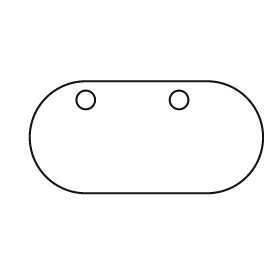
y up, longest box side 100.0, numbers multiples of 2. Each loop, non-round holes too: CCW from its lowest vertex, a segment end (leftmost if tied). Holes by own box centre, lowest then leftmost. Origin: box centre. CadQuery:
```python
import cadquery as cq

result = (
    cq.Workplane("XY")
    .moveTo(-26.0, -24.0)
    .lineTo(26.0, -24.0)
    .threePointArc((50.0, 0.0), (26.0, 24.0))
    .lineTo(-26.0, 24.0)
    .threePointArc((-50.0, 0.0), (-26.0, -24.0))
    .close()
    .moveTo(-26.0, 16.0)
    .circle(4.0)
    .moveTo(14.0, 16.0)
    .circle(4.0)
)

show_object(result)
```